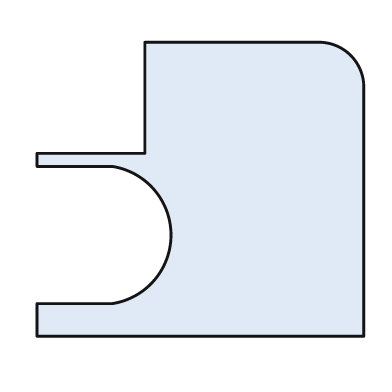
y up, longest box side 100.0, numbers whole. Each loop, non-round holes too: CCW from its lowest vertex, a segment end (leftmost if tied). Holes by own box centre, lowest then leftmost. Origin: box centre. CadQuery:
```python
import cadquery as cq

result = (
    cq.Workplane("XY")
    .moveTo(-50.0, -45.0)
    .lineTo(50.0, -45.0)
    .lineTo(50.0, 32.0)
    .threePointArc((46.0, 41.0), (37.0, 45.0))
    .lineTo(-17.0, 45.0)
    .lineTo(-17.0, 11.0)
    .lineTo(-50.0, 11.0)
    .lineTo(-50.0, 7.0)
    .lineTo(-27.0, 7.0)
    .threePointArc((-9.0, -14.0), (-27.0, -35.0))
    .lineTo(-50.0, -35.0)
    .close()
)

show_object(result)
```